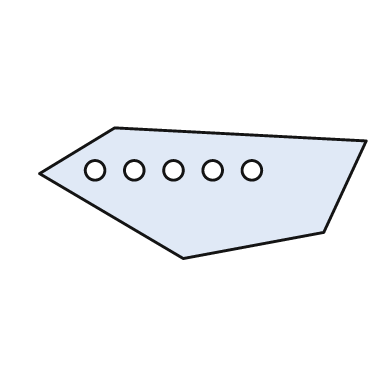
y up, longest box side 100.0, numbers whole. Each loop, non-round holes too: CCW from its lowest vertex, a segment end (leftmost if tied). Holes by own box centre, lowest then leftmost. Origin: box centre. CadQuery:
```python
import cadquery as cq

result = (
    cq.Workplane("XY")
    .moveTo(-6.0, -20.0)
    .lineTo(37.0, -12.0)
    .lineTo(50.0, 16.0)
    .lineTo(-27.0, 20.0)
    .lineTo(-50.0, 6.0)
    .close()
    .moveTo(-33.0, 7.0)
    .circle(3.0)
    .moveTo(-21.0, 7.0)
    .circle(3.0)
    .moveTo(-9.0, 7.0)
    .circle(3.0)
    .moveTo(3.0, 7.0)
    .circle(3.0)
    .moveTo(15.0, 7.0)
    .circle(3.0)
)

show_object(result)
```